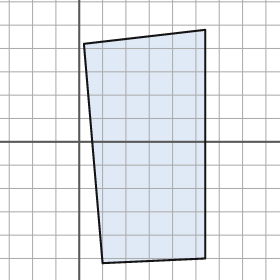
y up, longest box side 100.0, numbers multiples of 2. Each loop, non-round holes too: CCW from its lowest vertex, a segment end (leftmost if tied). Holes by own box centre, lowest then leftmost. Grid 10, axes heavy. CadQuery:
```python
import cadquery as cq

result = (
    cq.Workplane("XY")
    .moveTo(10.0, -52.0)
    .lineTo(54.0, -50.0)
    .lineTo(54.0, 48.0)
    .lineTo(2.0, 42.0)
    .close()
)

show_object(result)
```